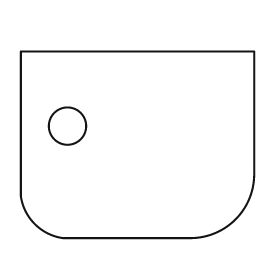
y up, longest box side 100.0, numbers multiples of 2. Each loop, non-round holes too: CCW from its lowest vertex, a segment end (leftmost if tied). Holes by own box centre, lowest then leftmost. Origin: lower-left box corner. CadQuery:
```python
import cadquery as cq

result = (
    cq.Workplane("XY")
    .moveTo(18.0, 0.0)
    .lineTo(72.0, 0.0)
    .threePointArc((92.0, 8.0), (100.0, 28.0))
    .lineTo(100.0, 80.0)
    .lineTo(0.0, 80.0)
    .lineTo(0.0, 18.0)
    .threePointArc((6.0, 6.0), (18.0, 0.0))
    .close()
    .moveTo(20.0, 48.0)
    .circle(8.0)
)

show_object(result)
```